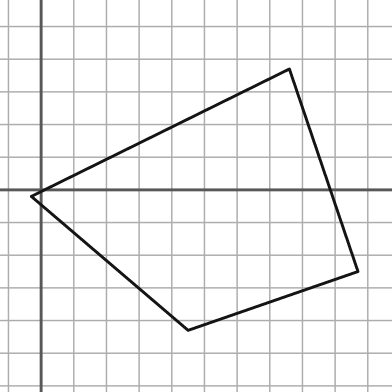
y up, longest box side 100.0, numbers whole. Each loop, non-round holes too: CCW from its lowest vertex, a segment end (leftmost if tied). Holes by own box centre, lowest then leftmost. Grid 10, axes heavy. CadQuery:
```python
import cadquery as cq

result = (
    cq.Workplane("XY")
    .moveTo(45.0, -43.0)
    .lineTo(97.0, -25.0)
    .lineTo(76.0, 37.0)
    .lineTo(-3.0, -2.0)
    .close()
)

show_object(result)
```